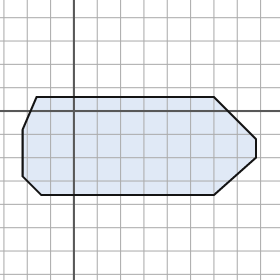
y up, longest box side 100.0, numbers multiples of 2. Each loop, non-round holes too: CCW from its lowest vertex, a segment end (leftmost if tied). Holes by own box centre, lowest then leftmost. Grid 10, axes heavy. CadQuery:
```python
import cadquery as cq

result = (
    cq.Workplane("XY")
    .moveTo(-14.0, -36.0)
    .lineTo(60.0, -36.0)
    .lineTo(78.0, -20.0)
    .lineTo(78.0, -12.0)
    .lineTo(60.0, 6.0)
    .lineTo(-16.0, 6.0)
    .lineTo(-22.0, -8.0)
    .lineTo(-22.0, -28.0)
    .close()
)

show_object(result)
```